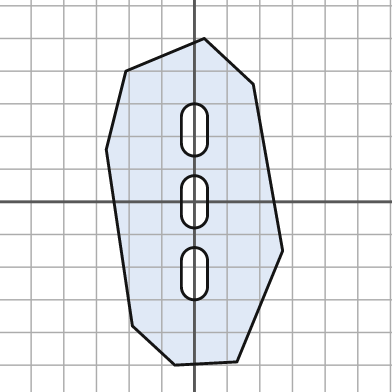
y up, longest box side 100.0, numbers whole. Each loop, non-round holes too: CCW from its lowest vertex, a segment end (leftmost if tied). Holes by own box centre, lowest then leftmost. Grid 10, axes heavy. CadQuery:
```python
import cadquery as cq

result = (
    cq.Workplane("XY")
    .moveTo(-6.0, -50.0)
    .lineTo(13.0, -49.0)
    .lineTo(27.0, -15.0)
    .lineTo(18.0, 36.0)
    .lineTo(3.0, 50.0)
    .lineTo(-21.0, 40.0)
    .lineTo(-27.0, 16.0)
    .lineTo(-19.0, -38.0)
    .close()
    .moveTo(-4.0, -26.0)
    .threePointArc((0.0, -30.0), (4.0, -26.0))
    .lineTo(4.0, -18.0)
    .threePointArc((0.0, -14.0), (-4.0, -18.0))
    .close()
    .moveTo(-4.0, -4.0)
    .threePointArc((0.0, -8.0), (4.0, -4.0))
    .lineTo(4.0, 4.0)
    .threePointArc((0.0, 8.0), (-4.0, 4.0))
    .close()
    .moveTo(-4.0, 18.0)
    .threePointArc((0.0, 14.0), (4.0, 18.0))
    .lineTo(4.0, 26.0)
    .threePointArc((0.0, 30.0), (-4.0, 26.0))
    .close()
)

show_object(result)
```